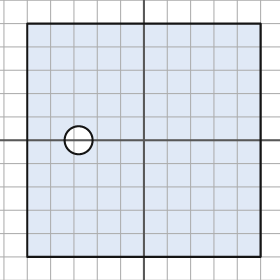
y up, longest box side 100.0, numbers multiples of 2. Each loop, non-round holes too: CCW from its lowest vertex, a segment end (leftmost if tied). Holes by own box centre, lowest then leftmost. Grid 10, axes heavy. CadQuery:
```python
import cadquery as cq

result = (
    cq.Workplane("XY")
    .moveTo(-50.0, -50.0)
    .lineTo(50.0, -50.0)
    .lineTo(50.0, 50.0)
    .lineTo(-50.0, 50.0)
    .close()
    .moveTo(-28.0, 0.0)
    .circle(6.0)
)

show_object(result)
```